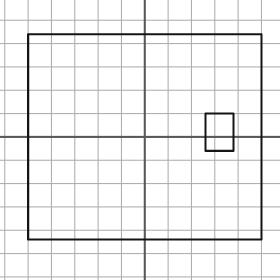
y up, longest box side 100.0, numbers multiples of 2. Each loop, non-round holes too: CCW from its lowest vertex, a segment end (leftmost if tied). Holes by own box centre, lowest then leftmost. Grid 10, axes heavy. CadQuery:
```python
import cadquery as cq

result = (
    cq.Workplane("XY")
    .moveTo(-50.0, -44.0)
    .lineTo(50.0, -44.0)
    .lineTo(50.0, 44.0)
    .lineTo(-50.0, 44.0)
    .close()
    .moveTo(26.0, -6.0)
    .lineTo(38.0, -6.0)
    .lineTo(38.0, 10.0)
    .lineTo(26.0, 10.0)
    .close()
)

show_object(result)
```